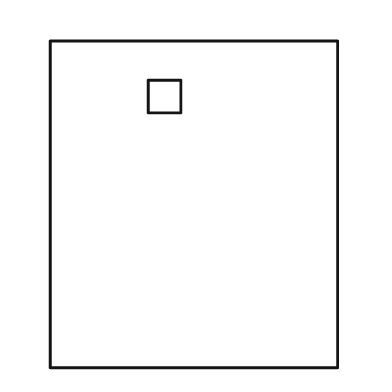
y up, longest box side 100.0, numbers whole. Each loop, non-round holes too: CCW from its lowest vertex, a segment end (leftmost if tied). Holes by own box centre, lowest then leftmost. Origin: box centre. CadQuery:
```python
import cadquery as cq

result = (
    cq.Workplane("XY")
    .moveTo(-44.0, -50.0)
    .lineTo(44.0, -50.0)
    .lineTo(44.0, 50.0)
    .lineTo(-44.0, 50.0)
    .close()
    .moveTo(-14.0, 28.0)
    .lineTo(-4.0, 28.0)
    .lineTo(-4.0, 38.0)
    .lineTo(-14.0, 38.0)
    .close()
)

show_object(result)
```